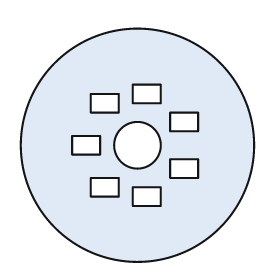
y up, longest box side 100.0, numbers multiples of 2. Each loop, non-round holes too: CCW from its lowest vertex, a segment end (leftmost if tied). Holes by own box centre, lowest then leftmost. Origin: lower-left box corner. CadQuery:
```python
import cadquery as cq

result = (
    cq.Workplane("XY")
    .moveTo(50.0, 50.0)
    .circle(50.0)
    .moveTo(48.0, 24.0)
    .lineTo(60.0, 24.0)
    .lineTo(60.0, 32.0)
    .lineTo(48.0, 32.0)
    .close()
    .moveTo(30.0, 28.0)
    .lineTo(42.0, 28.0)
    .lineTo(42.0, 36.0)
    .lineTo(30.0, 36.0)
    .close()
    .moveTo(64.0, 36.0)
    .lineTo(76.0, 36.0)
    .lineTo(76.0, 44.0)
    .lineTo(64.0, 44.0)
    .close()
    .moveTo(22.0, 46.0)
    .lineTo(34.0, 46.0)
    .lineTo(34.0, 54.0)
    .lineTo(22.0, 54.0)
    .close()
    .moveTo(50.0, 50.0)
    .circle(10.0)
    .moveTo(64.0, 56.0)
    .lineTo(76.0, 56.0)
    .lineTo(76.0, 64.0)
    .lineTo(64.0, 64.0)
    .close()
    .moveTo(30.0, 64.0)
    .lineTo(42.0, 64.0)
    .lineTo(42.0, 72.0)
    .lineTo(30.0, 72.0)
    .close()
    .moveTo(48.0, 68.0)
    .lineTo(60.0, 68.0)
    .lineTo(60.0, 76.0)
    .lineTo(48.0, 76.0)
    .close()
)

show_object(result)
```